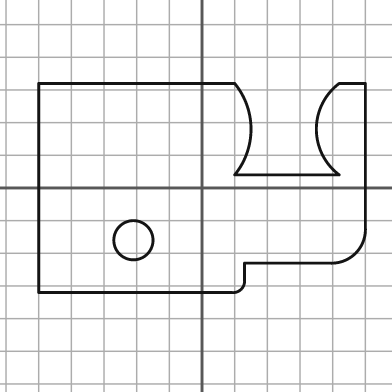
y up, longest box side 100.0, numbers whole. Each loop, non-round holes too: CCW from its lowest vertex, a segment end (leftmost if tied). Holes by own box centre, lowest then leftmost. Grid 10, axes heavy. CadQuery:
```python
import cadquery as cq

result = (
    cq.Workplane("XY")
    .moveTo(-50.0, -32.0)
    .lineTo(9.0, -32.0)
    .threePointArc((12.0, -31.0), (13.0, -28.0))
    .lineTo(13.0, -23.0)
    .lineTo(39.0, -23.0)
    .threePointArc((47.0, -20.0), (50.0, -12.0))
    .lineTo(50.0, 32.0)
    .lineTo(42.0, 32.0)
    .threePointArc((35.0, 18.0), (42.0, 4.0))
    .lineTo(10.0, 4.0)
    .threePointArc((15.0, 18.0), (10.0, 32.0))
    .lineTo(-50.0, 32.0)
    .close()
    .moveTo(-21.0, -16.0)
    .circle(6.0)
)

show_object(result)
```